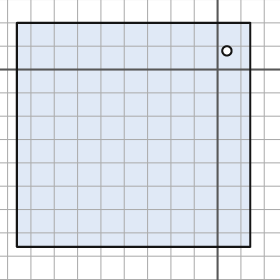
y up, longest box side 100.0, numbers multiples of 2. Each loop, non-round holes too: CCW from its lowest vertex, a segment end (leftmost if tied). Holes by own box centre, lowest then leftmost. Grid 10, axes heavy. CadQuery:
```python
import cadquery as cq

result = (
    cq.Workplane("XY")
    .moveTo(-86.0, -76.0)
    .lineTo(14.0, -76.0)
    .lineTo(14.0, 20.0)
    .lineTo(-86.0, 20.0)
    .close()
    .moveTo(4.0, 8.0)
    .circle(2.0)
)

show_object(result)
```